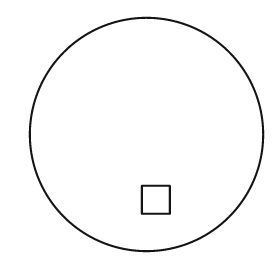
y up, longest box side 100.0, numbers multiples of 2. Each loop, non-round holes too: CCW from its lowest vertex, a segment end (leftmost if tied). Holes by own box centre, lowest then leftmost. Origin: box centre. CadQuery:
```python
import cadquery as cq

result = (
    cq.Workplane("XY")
    .moveTo(0.0, 0.0)
    .circle(50.0)
    .moveTo(-2.0, -34.0)
    .lineTo(10.0, -34.0)
    .lineTo(10.0, -22.0)
    .lineTo(-2.0, -22.0)
    .close()
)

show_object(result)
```